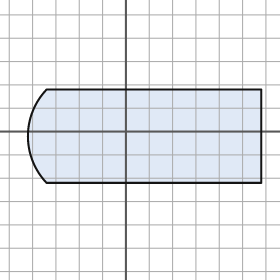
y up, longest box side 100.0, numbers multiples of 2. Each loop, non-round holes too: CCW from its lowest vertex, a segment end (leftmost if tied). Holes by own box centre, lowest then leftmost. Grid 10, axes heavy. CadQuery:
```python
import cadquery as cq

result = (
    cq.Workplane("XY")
    .moveTo(-34.0, -22.0)
    .lineTo(58.0, -22.0)
    .lineTo(58.0, 18.0)
    .lineTo(-34.0, 18.0)
    .threePointArc((-42.0, -2.0), (-34.0, -22.0))
    .close()
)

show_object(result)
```